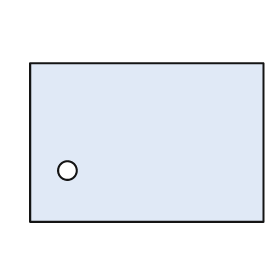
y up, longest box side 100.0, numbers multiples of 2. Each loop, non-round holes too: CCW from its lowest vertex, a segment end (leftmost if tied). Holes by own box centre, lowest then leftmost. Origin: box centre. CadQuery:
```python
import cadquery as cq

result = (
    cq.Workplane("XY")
    .moveTo(-50.0, -34.0)
    .lineTo(50.0, -34.0)
    .lineTo(50.0, 34.0)
    .lineTo(-50.0, 34.0)
    .close()
    .moveTo(-34.0, -12.0)
    .circle(4.0)
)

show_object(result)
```